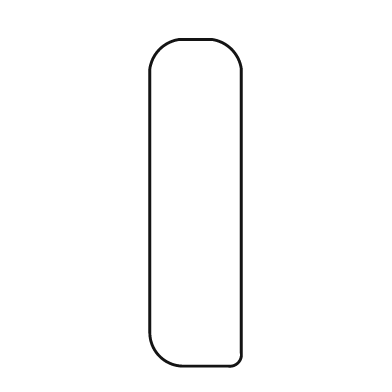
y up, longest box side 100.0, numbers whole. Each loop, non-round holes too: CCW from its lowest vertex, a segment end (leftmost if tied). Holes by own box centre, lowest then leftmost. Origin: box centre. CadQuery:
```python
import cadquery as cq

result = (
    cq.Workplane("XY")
    .moveTo(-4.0, -50.0)
    .lineTo(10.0, -50.0)
    .threePointArc((13.0, -49.0), (14.0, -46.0))
    .lineTo(14.0, 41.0)
    .threePointArc((11.0, 47.0), (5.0, 50.0))
    .lineTo(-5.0, 50.0)
    .threePointArc((-11.0, 47.0), (-14.0, 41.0))
    .lineTo(-14.0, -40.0)
    .threePointArc((-11.0, -47.0), (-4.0, -50.0))
    .close()
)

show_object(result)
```